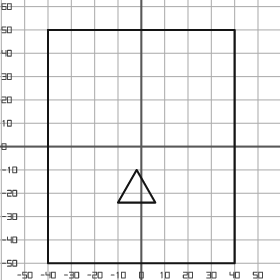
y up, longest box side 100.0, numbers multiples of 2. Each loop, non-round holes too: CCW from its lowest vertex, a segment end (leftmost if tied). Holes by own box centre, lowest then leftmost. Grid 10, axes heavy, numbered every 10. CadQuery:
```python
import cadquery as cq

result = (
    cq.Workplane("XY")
    .moveTo(-40.0, -50.0)
    .lineTo(40.0, -50.0)
    .lineTo(40.0, 50.0)
    .lineTo(-40.0, 50.0)
    .close()
    .moveTo(-10.0, -24.0)
    .lineTo(6.0, -24.0)
    .lineTo(-2.0, -10.0)
    .close()
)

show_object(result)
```